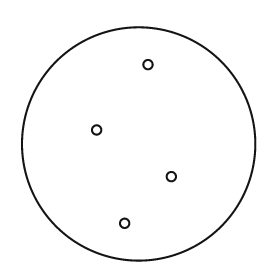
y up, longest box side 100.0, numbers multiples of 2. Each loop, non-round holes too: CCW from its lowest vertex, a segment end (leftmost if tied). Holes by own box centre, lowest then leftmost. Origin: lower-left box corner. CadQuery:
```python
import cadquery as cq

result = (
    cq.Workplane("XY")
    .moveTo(50.0, 50.0)
    .circle(50.0)
    .moveTo(44.0, 16.0)
    .circle(2.0)
    .moveTo(64.0, 36.0)
    .circle(2.0)
    .moveTo(32.0, 56.0)
    .circle(2.0)
    .moveTo(54.0, 84.0)
    .circle(2.0)
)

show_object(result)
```